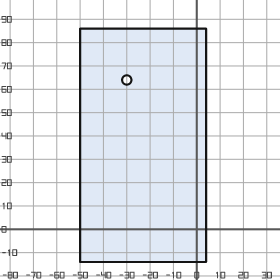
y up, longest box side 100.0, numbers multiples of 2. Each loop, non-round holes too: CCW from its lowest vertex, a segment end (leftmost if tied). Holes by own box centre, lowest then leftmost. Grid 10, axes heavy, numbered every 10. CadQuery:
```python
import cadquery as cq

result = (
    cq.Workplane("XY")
    .moveTo(-50.0, -14.0)
    .lineTo(4.0, -14.0)
    .lineTo(4.0, 86.0)
    .lineTo(-50.0, 86.0)
    .close()
    .moveTo(-30.0, 64.0)
    .circle(2.0)
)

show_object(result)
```